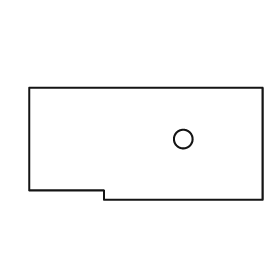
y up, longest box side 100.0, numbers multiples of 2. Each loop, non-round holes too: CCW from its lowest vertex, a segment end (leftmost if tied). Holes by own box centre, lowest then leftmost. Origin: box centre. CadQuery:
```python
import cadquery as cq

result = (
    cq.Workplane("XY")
    .moveTo(-18.0, -24.0)
    .lineTo(50.0, -24.0)
    .lineTo(50.0, 24.0)
    .lineTo(-50.0, 24.0)
    .lineTo(-50.0, -20.0)
    .lineTo(-18.0, -20.0)
    .close()
    .moveTo(16.0, 2.0)
    .circle(4.0)
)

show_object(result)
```